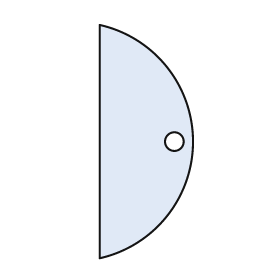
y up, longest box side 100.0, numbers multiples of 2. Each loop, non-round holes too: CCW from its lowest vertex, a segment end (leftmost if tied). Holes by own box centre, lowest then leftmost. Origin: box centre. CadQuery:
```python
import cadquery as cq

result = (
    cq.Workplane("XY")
    .moveTo(-20.0, -50.0)
    .threePointArc((20.0, 0.0), (-20.0, 50.0))
    .close()
    .moveTo(12.0, 0.0)
    .circle(4.0)
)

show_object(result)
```